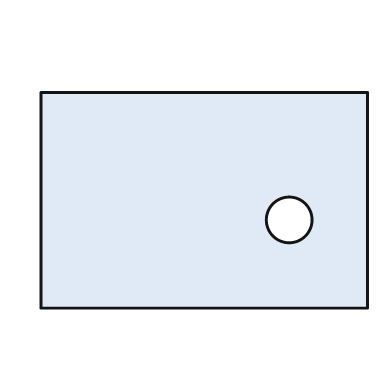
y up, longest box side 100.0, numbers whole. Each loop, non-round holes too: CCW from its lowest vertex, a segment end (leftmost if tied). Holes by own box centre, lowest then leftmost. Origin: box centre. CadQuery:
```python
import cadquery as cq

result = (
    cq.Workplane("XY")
    .moveTo(-50.0, -33.0)
    .lineTo(50.0, -33.0)
    .lineTo(50.0, 33.0)
    .lineTo(-50.0, 33.0)
    .close()
    .moveTo(26.0, -6.0)
    .circle(7.0)
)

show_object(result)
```